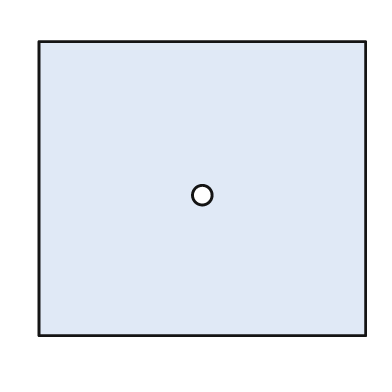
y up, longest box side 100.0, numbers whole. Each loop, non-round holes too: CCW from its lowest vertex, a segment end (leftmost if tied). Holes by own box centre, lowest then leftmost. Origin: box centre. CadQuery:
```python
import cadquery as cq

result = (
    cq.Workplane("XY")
    .moveTo(-50.0, -45.0)
    .lineTo(50.0, -45.0)
    .lineTo(50.0, 45.0)
    .lineTo(-50.0, 45.0)
    .close()
    .moveTo(0.0, -2.0)
    .circle(3.0)
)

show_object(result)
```